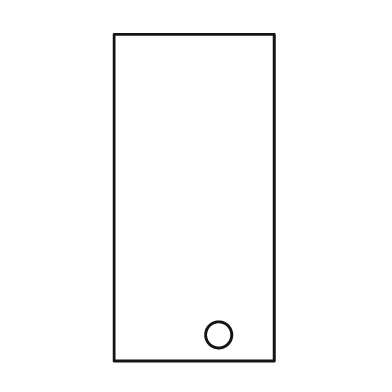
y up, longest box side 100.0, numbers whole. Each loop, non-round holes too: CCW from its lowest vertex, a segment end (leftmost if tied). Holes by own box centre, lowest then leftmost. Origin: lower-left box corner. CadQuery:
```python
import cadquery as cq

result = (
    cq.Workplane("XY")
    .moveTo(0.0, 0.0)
    .lineTo(49.0, 0.0)
    .lineTo(49.0, 100.0)
    .lineTo(0.0, 100.0)
    .close()
    .moveTo(32.0, 8.0)
    .circle(4.0)
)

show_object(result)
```